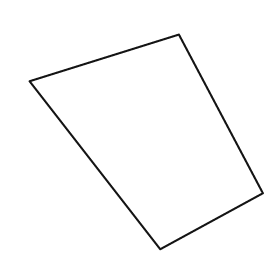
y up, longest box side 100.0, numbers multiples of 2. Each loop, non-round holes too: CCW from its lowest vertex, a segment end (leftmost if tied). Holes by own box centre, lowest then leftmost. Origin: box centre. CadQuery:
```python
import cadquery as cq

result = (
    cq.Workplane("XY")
    .moveTo(6.0, -46.0)
    .lineTo(50.0, -22.0)
    .lineTo(14.0, 46.0)
    .lineTo(-50.0, 26.0)
    .close()
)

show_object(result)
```